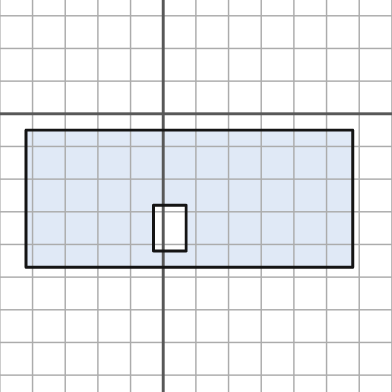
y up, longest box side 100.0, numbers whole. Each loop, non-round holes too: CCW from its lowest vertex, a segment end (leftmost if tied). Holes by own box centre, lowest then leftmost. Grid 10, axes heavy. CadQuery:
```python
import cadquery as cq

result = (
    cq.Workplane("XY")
    .moveTo(-42.0, -47.0)
    .lineTo(58.0, -47.0)
    .lineTo(58.0, -5.0)
    .lineTo(-42.0, -5.0)
    .close()
    .moveTo(-3.0, -42.0)
    .lineTo(7.0, -42.0)
    .lineTo(7.0, -28.0)
    .lineTo(-3.0, -28.0)
    .close()
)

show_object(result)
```